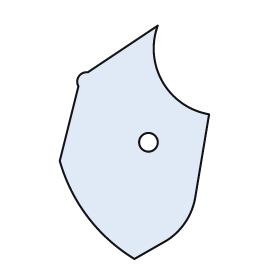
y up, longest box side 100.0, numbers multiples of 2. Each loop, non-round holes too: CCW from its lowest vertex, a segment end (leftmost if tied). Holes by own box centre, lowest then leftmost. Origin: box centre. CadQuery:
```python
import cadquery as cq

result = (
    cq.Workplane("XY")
    .moveTo(0.0, -50.0)
    .lineTo(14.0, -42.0)
    .threePointArc((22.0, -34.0), (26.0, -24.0))
    .lineTo(32.0, 12.0)
    .threePointArc((12.0, 26.0), (10.0, 50.0))
    .lineTo(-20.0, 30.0)
    .threePointArc((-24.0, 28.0), (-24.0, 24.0))
    .lineTo(-32.0, -8.0)
    .threePointArc((-20.0, -32.0), (0.0, -50.0))
    .close()
    .moveTo(6.0, 0.0)
    .circle(4.0)
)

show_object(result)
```